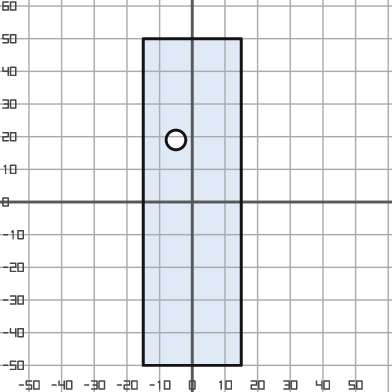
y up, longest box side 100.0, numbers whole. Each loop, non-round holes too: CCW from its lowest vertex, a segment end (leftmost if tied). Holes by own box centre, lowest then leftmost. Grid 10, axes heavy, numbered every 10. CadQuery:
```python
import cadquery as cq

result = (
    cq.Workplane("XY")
    .moveTo(-15.0, -50.0)
    .lineTo(15.0, -50.0)
    .lineTo(15.0, 50.0)
    .lineTo(-15.0, 50.0)
    .close()
    .moveTo(-5.0, 19.0)
    .circle(3.0)
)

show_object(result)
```